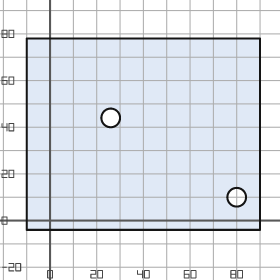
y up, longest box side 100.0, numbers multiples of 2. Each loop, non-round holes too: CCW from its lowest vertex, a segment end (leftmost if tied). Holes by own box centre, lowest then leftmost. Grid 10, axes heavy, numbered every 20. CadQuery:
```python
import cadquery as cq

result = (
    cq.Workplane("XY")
    .moveTo(-10.0, -4.0)
    .lineTo(90.0, -4.0)
    .lineTo(90.0, 78.0)
    .lineTo(-10.0, 78.0)
    .close()
    .moveTo(80.0, 10.0)
    .circle(4.0)
    .moveTo(26.0, 44.0)
    .circle(4.0)
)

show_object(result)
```